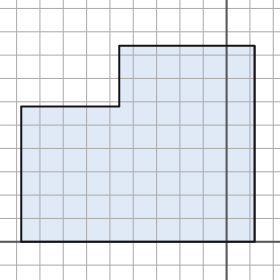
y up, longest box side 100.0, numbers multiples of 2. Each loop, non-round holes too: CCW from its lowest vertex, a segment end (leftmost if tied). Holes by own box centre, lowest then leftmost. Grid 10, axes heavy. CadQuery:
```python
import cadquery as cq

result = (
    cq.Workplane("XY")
    .moveTo(-88.0, 0.0)
    .lineTo(12.0, 0.0)
    .lineTo(12.0, 84.0)
    .lineTo(-46.0, 84.0)
    .lineTo(-46.0, 58.0)
    .lineTo(-88.0, 58.0)
    .close()
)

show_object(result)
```